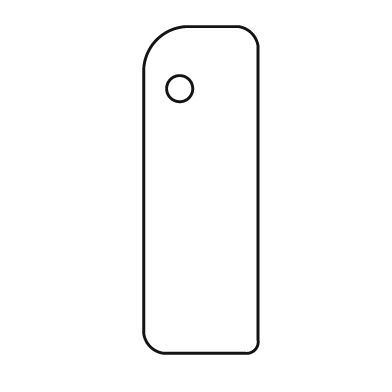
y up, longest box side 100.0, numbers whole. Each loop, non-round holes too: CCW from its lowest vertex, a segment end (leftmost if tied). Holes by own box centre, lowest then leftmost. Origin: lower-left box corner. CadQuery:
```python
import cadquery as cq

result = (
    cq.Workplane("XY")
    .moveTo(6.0, 0.0)
    .lineTo(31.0, 0.0)
    .threePointArc((34.0, 1.0), (35.0, 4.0))
    .lineTo(35.0, 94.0)
    .threePointArc((33.0, 98.0), (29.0, 100.0))
    .lineTo(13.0, 100.0)
    .threePointArc((4.0, 96.0), (0.0, 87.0))
    .lineTo(0.0, 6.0)
    .threePointArc((2.0, 2.0), (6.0, 0.0))
    .close()
    .moveTo(11.0, 81.0)
    .circle(4.0)
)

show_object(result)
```